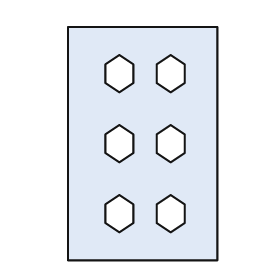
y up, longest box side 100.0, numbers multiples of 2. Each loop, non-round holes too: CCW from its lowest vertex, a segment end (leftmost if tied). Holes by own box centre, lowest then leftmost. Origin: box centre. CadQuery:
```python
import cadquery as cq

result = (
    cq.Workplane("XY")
    .moveTo(-32.0, -50.0)
    .lineTo(32.0, -50.0)
    .lineTo(32.0, 50.0)
    .lineTo(-32.0, 50.0)
    .close()
    .moveTo(-10.0, -38.0)
    .lineTo(-4.0, -34.0)
    .lineTo(-4.0, -26.0)
    .lineTo(-10.0, -22.0)
    .lineTo(-16.0, -26.0)
    .lineTo(-16.0, -34.0)
    .close()
    .moveTo(12.0, -38.0)
    .lineTo(18.0, -34.0)
    .lineTo(18.0, -26.0)
    .lineTo(12.0, -22.0)
    .lineTo(6.0, -26.0)
    .lineTo(6.0, -34.0)
    .close()
    .moveTo(-10.0, -8.0)
    .lineTo(-4.0, -4.0)
    .lineTo(-4.0, 4.0)
    .lineTo(-10.0, 8.0)
    .lineTo(-16.0, 4.0)
    .lineTo(-16.0, -4.0)
    .close()
    .moveTo(12.0, -8.0)
    .lineTo(18.0, -4.0)
    .lineTo(18.0, 4.0)
    .lineTo(12.0, 8.0)
    .lineTo(6.0, 4.0)
    .lineTo(6.0, -4.0)
    .close()
    .moveTo(-10.0, 22.0)
    .lineTo(-4.0, 26.0)
    .lineTo(-4.0, 34.0)
    .lineTo(-10.0, 38.0)
    .lineTo(-16.0, 34.0)
    .lineTo(-16.0, 26.0)
    .close()
    .moveTo(12.0, 22.0)
    .lineTo(18.0, 26.0)
    .lineTo(18.0, 34.0)
    .lineTo(12.0, 38.0)
    .lineTo(6.0, 34.0)
    .lineTo(6.0, 26.0)
    .close()
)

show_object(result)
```